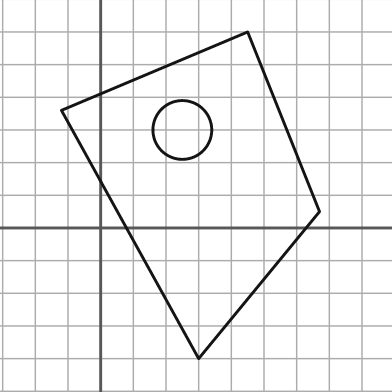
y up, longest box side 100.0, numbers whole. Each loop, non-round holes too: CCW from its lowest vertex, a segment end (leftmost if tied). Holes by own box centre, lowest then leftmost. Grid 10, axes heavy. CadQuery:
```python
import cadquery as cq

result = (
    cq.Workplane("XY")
    .moveTo(30.0, -40.0)
    .lineTo(67.0, 5.0)
    .lineTo(45.0, 60.0)
    .lineTo(-12.0, 36.0)
    .close()
    .moveTo(25.0, 30.0)
    .circle(9.0)
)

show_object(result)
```